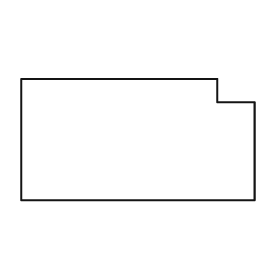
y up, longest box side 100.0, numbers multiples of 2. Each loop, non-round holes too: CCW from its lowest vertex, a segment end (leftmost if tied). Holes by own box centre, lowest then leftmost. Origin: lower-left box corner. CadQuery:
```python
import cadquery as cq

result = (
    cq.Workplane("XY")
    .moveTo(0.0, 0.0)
    .lineTo(100.0, 0.0)
    .lineTo(100.0, 42.0)
    .lineTo(84.0, 42.0)
    .lineTo(84.0, 52.0)
    .lineTo(0.0, 52.0)
    .close()
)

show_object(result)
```